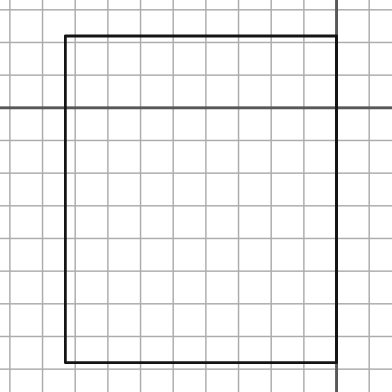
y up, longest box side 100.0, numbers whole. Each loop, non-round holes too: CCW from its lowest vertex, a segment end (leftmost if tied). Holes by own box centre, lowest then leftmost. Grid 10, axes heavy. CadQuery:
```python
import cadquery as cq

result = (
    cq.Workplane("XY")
    .moveTo(-83.0, -78.0)
    .lineTo(0.0, -78.0)
    .lineTo(0.0, 22.0)
    .lineTo(-83.0, 22.0)
    .close()
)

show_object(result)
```